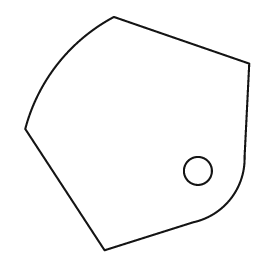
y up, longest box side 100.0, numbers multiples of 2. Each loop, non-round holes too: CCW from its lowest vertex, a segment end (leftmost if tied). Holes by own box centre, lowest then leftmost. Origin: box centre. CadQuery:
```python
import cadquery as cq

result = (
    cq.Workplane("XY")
    .moveTo(-14.0, -50.0)
    .lineTo(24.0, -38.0)
    .threePointArc((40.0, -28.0), (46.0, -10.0))
    .lineTo(48.0, 30.0)
    .lineTo(-10.0, 50.0)
    .threePointArc((-34.0, 30.0), (-48.0, 2.0))
    .close()
    .moveTo(26.0, -16.0)
    .circle(6.0)
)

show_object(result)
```